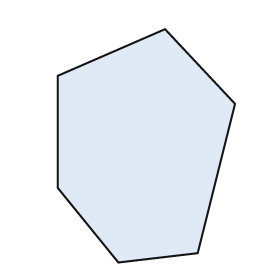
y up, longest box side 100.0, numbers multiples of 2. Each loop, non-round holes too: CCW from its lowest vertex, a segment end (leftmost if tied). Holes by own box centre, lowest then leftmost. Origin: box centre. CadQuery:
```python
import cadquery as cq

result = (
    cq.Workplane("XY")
    .moveTo(-12.0, -50.0)
    .lineTo(22.0, -46.0)
    .lineTo(38.0, 18.0)
    .lineTo(8.0, 50.0)
    .lineTo(-38.0, 30.0)
    .lineTo(-38.0, -18.0)
    .close()
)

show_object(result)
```